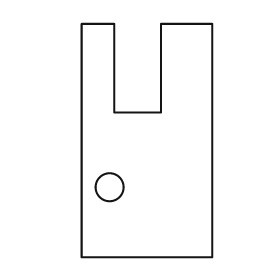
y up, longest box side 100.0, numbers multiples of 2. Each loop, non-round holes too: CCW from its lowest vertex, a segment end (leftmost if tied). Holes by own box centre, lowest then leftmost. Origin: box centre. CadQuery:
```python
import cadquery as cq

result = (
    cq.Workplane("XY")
    .moveTo(-28.0, -50.0)
    .lineTo(28.0, -50.0)
    .lineTo(28.0, 50.0)
    .lineTo(6.0, 50.0)
    .lineTo(6.0, 12.0)
    .lineTo(-14.0, 12.0)
    .lineTo(-14.0, 50.0)
    .lineTo(-28.0, 50.0)
    .close()
    .moveTo(-16.0, -20.0)
    .circle(6.0)
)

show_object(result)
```